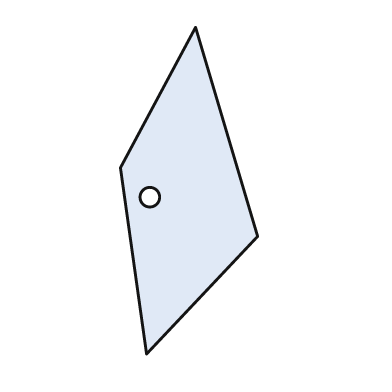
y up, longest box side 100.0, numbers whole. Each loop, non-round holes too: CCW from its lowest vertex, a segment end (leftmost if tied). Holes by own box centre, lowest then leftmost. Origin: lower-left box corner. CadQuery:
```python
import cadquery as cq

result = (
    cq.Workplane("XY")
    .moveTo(8.0, 0.0)
    .lineTo(42.0, 36.0)
    .lineTo(23.0, 100.0)
    .lineTo(0.0, 57.0)
    .close()
    .moveTo(9.0, 48.0)
    .circle(3.0)
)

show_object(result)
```